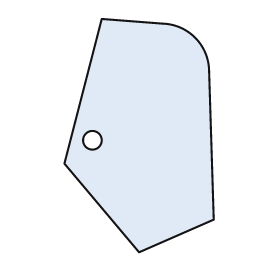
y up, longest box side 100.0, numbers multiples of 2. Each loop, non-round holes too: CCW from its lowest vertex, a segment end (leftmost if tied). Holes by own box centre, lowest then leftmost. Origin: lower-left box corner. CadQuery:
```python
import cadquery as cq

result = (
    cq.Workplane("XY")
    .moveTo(32.0, 0.0)
    .lineTo(64.0, 14.0)
    .lineTo(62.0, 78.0)
    .threePointArc((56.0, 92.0), (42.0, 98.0))
    .lineTo(16.0, 100.0)
    .lineTo(0.0, 38.0)
    .close()
    .moveTo(12.0, 48.0)
    .circle(4.0)
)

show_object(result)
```